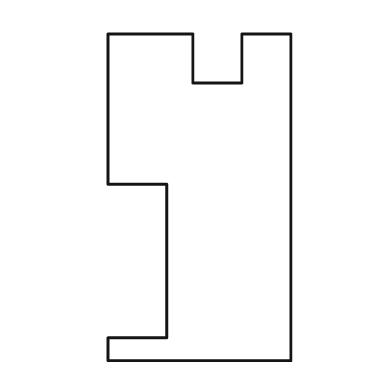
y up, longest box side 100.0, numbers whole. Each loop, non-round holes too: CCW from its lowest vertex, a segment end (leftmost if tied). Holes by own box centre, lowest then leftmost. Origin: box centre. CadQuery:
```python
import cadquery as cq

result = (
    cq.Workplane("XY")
    .moveTo(-28.0, -50.0)
    .lineTo(28.0, -50.0)
    .lineTo(28.0, 50.0)
    .lineTo(13.0, 50.0)
    .lineTo(13.0, 35.0)
    .lineTo(-2.0, 35.0)
    .lineTo(-2.0, 50.0)
    .lineTo(-28.0, 50.0)
    .lineTo(-28.0, 4.0)
    .lineTo(-10.0, 4.0)
    .lineTo(-10.0, -43.0)
    .lineTo(-28.0, -43.0)
    .close()
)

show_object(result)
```